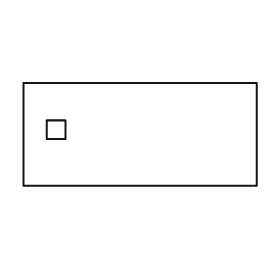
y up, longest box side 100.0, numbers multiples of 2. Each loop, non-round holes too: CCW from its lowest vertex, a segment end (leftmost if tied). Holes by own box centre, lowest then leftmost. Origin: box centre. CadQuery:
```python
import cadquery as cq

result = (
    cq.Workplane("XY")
    .moveTo(-50.0, -22.0)
    .lineTo(50.0, -22.0)
    .lineTo(50.0, 22.0)
    .lineTo(-50.0, 22.0)
    .close()
    .moveTo(-40.0, -2.0)
    .lineTo(-32.0, -2.0)
    .lineTo(-32.0, 6.0)
    .lineTo(-40.0, 6.0)
    .close()
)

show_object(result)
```